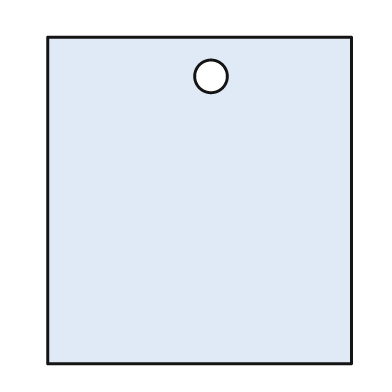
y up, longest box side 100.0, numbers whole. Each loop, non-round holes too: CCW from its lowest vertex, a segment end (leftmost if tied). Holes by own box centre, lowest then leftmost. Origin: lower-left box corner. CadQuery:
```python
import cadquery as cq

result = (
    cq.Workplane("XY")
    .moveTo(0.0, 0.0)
    .lineTo(93.0, 0.0)
    .lineTo(93.0, 100.0)
    .lineTo(0.0, 100.0)
    .close()
    .moveTo(50.0, 88.0)
    .circle(5.0)
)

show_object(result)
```